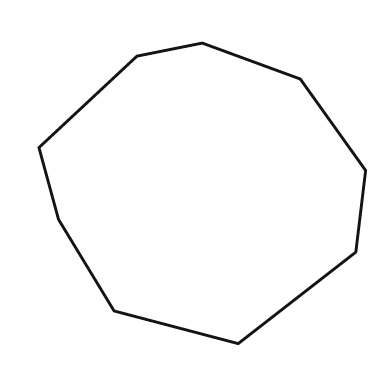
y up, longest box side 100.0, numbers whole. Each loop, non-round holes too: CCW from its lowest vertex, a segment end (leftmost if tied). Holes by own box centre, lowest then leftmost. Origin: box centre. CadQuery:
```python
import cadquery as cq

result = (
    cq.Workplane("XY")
    .moveTo(11.0, -46.0)
    .lineTo(47.0, -18.0)
    .lineTo(50.0, 7.0)
    .lineTo(30.0, 35.0)
    .lineTo(0.0, 46.0)
    .lineTo(-20.0, 42.0)
    .lineTo(-50.0, 14.0)
    .lineTo(-44.0, -8.0)
    .lineTo(-27.0, -36.0)
    .close()
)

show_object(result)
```